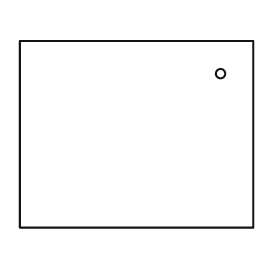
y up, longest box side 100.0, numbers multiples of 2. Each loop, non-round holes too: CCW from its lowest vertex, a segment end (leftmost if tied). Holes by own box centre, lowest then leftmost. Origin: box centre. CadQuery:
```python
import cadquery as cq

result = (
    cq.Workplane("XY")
    .moveTo(-50.0, -40.0)
    .lineTo(50.0, -40.0)
    .lineTo(50.0, 40.0)
    .lineTo(-50.0, 40.0)
    .close()
    .moveTo(36.0, 26.0)
    .circle(2.0)
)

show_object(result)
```